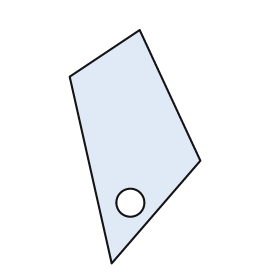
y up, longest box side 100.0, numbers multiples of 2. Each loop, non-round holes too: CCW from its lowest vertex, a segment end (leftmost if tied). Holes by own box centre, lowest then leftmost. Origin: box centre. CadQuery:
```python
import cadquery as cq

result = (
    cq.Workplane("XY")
    .moveTo(-10.0, -50.0)
    .lineTo(28.0, -6.0)
    .lineTo(2.0, 50.0)
    .lineTo(-28.0, 30.0)
    .close()
    .moveTo(-2.0, -24.0)
    .circle(6.0)
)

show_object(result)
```